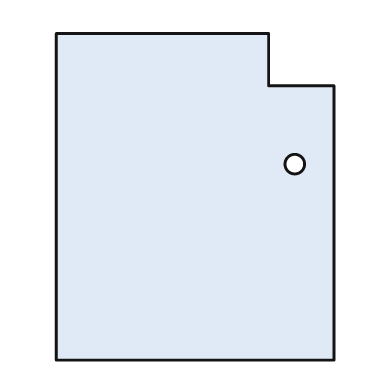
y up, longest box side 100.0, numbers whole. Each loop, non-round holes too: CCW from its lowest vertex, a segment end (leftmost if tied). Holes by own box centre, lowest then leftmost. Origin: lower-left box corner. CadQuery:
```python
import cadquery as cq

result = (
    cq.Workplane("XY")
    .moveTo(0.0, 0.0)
    .lineTo(85.0, 0.0)
    .lineTo(85.0, 84.0)
    .lineTo(65.0, 84.0)
    .lineTo(65.0, 100.0)
    .lineTo(0.0, 100.0)
    .close()
    .moveTo(73.0, 60.0)
    .circle(3.0)
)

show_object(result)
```